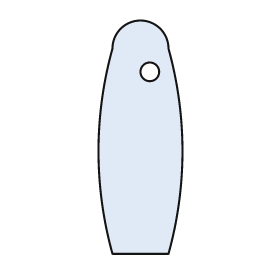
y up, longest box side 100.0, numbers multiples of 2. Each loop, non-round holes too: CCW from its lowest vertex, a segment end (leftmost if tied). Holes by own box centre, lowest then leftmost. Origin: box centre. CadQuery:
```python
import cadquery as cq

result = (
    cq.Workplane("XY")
    .moveTo(-12.0, -50.0)
    .lineTo(12.0, -50.0)
    .threePointArc((18.0, -6.0), (12.0, 38.0))
    .threePointArc((0.0, 50.0), (-12.0, 38.0))
    .threePointArc((-18.0, -6.0), (-12.0, -50.0))
    .close()
    .moveTo(4.0, 28.0)
    .circle(4.0)
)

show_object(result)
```